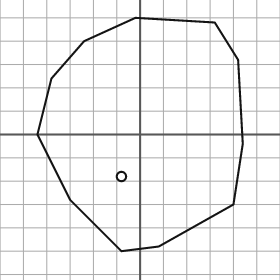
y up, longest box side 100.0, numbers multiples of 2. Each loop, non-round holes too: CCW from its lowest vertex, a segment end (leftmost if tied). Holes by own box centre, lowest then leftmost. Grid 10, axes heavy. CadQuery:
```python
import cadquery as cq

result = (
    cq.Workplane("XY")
    .moveTo(-8.0, -50.0)
    .lineTo(8.0, -48.0)
    .lineTo(40.0, -30.0)
    .lineTo(44.0, -4.0)
    .lineTo(42.0, 32.0)
    .lineTo(32.0, 48.0)
    .lineTo(-2.0, 50.0)
    .lineTo(-24.0, 40.0)
    .lineTo(-38.0, 24.0)
    .lineTo(-44.0, 0.0)
    .lineTo(-30.0, -28.0)
    .close()
    .moveTo(-8.0, -18.0)
    .circle(2.0)
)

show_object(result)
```